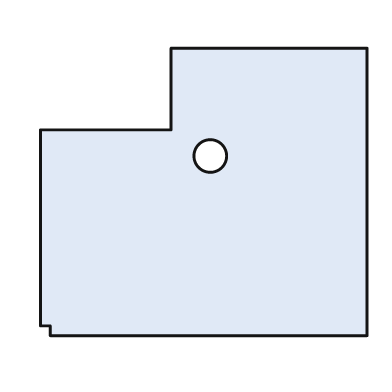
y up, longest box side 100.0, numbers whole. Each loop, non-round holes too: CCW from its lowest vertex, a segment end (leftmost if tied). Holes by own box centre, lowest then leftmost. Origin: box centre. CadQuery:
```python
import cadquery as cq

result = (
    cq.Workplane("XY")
    .moveTo(-47.0, -44.0)
    .lineTo(50.0, -44.0)
    .lineTo(50.0, 44.0)
    .lineTo(-10.0, 44.0)
    .lineTo(-10.0, 19.0)
    .lineTo(-50.0, 19.0)
    .lineTo(-50.0, -41.0)
    .lineTo(-47.0, -41.0)
    .close()
    .moveTo(2.0, 11.0)
    .circle(5.0)
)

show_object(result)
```